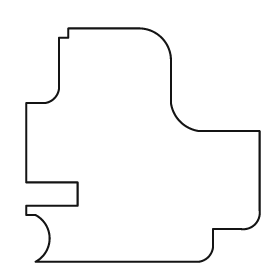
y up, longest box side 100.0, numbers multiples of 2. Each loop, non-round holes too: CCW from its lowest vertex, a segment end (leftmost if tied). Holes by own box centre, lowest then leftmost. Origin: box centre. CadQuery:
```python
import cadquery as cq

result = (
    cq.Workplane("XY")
    .moveTo(-46.0, -50.0)
    .lineTo(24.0, -50.0)
    .threePointArc((28.0, -48.0), (30.0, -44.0))
    .lineTo(30.0, -36.0)
    .lineTo(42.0, -36.0)
    .threePointArc((48.0, -34.0), (50.0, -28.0))
    .lineTo(50.0, 6.0)
    .lineTo(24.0, 6.0)
    .threePointArc((16.0, 10.0), (12.0, 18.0))
    .lineTo(12.0, 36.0)
    .threePointArc((8.0, 46.0), (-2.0, 50.0))
    .lineTo(-32.0, 50.0)
    .lineTo(-32.0, 46.0)
    .lineTo(-36.0, 46.0)
    .lineTo(-36.0, 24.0)
    .threePointArc((-38.0, 20.0), (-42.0, 18.0))
    .lineTo(-50.0, 18.0)
    .lineTo(-50.0, -16.0)
    .lineTo(-28.0, -16.0)
    .lineTo(-28.0, -26.0)
    .lineTo(-50.0, -26.0)
    .lineTo(-50.0, -30.0)
    .lineTo(-46.0, -30.0)
    .threePointArc((-40.0, -40.0), (-46.0, -50.0))
    .close()
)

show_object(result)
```